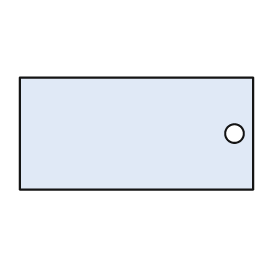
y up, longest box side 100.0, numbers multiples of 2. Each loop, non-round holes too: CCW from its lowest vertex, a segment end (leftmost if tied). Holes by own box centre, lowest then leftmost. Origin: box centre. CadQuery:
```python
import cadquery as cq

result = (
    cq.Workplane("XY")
    .moveTo(-50.0, -24.0)
    .lineTo(50.0, -24.0)
    .lineTo(50.0, 24.0)
    .lineTo(-50.0, 24.0)
    .close()
    .moveTo(42.0, 0.0)
    .circle(4.0)
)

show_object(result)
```